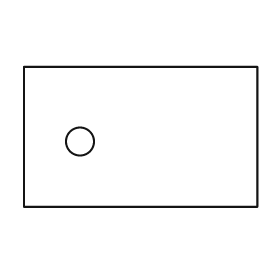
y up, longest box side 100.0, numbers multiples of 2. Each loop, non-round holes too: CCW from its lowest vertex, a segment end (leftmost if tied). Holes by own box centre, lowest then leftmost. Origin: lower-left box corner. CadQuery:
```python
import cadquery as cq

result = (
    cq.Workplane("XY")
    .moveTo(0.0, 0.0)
    .lineTo(100.0, 0.0)
    .lineTo(100.0, 60.0)
    .lineTo(0.0, 60.0)
    .close()
    .moveTo(24.0, 28.0)
    .circle(6.0)
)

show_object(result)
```